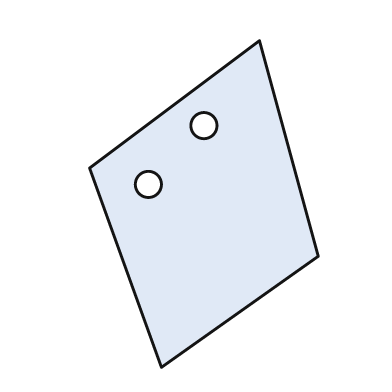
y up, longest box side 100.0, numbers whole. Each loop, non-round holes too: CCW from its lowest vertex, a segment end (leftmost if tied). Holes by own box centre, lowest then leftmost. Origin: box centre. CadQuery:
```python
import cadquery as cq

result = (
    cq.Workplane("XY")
    .moveTo(-13.0, -50.0)
    .lineTo(35.0, -16.0)
    .lineTo(17.0, 50.0)
    .lineTo(-35.0, 11.0)
    .close()
    .moveTo(-17.0, 6.0)
    .circle(4.0)
    .moveTo(0.0, 24.0)
    .circle(4.0)
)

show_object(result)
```